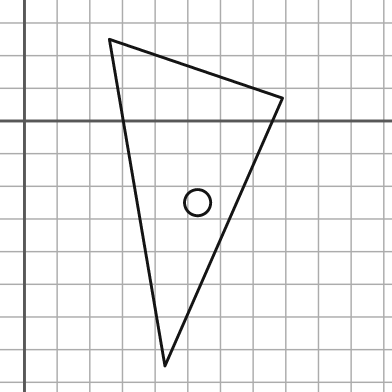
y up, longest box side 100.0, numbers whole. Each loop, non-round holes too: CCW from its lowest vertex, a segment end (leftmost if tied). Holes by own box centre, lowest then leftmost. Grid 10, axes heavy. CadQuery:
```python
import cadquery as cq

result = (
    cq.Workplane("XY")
    .moveTo(43.0, -75.0)
    .lineTo(79.0, 7.0)
    .lineTo(26.0, 25.0)
    .close()
    .moveTo(53.0, -25.0)
    .circle(4.0)
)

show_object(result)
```